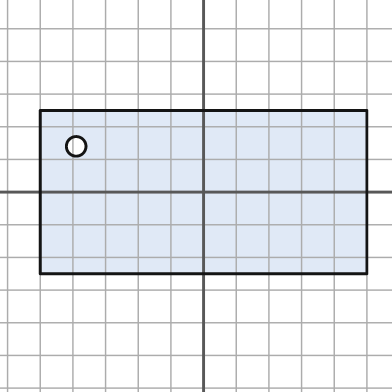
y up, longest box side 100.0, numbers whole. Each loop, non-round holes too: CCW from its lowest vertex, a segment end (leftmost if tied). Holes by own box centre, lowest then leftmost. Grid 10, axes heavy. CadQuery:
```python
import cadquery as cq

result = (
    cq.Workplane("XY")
    .moveTo(-50.0, -25.0)
    .lineTo(50.0, -25.0)
    .lineTo(50.0, 25.0)
    .lineTo(-50.0, 25.0)
    .close()
    .moveTo(-39.0, 14.0)
    .circle(3.0)
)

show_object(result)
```